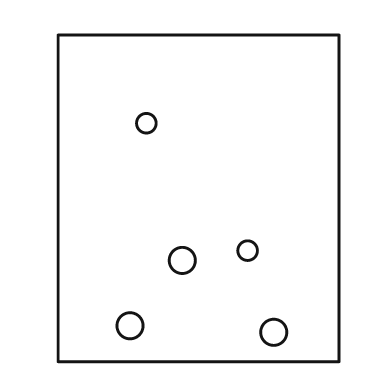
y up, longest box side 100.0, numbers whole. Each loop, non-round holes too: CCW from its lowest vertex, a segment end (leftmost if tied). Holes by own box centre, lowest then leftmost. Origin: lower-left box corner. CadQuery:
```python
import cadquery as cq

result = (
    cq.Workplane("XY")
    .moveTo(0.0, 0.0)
    .lineTo(86.0, 0.0)
    .lineTo(86.0, 100.0)
    .lineTo(0.0, 100.0)
    .close()
    .moveTo(66.0, 9.0)
    .circle(4.0)
    .moveTo(22.0, 11.0)
    .circle(4.0)
    .moveTo(38.0, 31.0)
    .circle(4.0)
    .moveTo(58.0, 34.0)
    .circle(3.0)
    .moveTo(27.0, 73.0)
    .circle(3.0)
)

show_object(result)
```